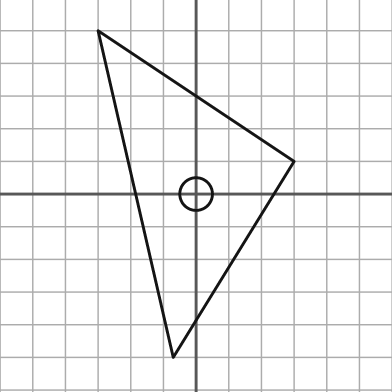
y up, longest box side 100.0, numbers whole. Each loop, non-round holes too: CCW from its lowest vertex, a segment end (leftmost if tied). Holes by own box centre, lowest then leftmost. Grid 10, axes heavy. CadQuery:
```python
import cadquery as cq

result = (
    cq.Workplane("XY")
    .moveTo(-7.0, -50.0)
    .lineTo(30.0, 10.0)
    .lineTo(-30.0, 50.0)
    .close()
    .moveTo(0.0, 0.0)
    .circle(5.0)
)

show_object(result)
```